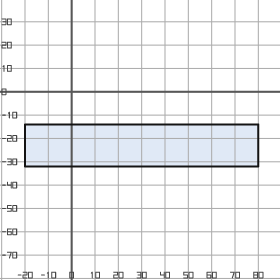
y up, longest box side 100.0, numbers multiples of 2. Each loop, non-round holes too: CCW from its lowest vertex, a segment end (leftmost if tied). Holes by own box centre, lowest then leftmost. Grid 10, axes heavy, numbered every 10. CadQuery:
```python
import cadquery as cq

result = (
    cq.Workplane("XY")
    .moveTo(-20.0, -32.0)
    .lineTo(80.0, -32.0)
    .lineTo(80.0, -14.0)
    .lineTo(-20.0, -14.0)
    .close()
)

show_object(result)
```